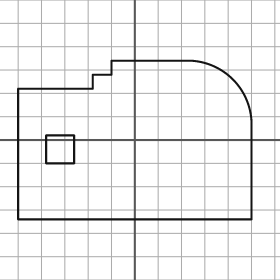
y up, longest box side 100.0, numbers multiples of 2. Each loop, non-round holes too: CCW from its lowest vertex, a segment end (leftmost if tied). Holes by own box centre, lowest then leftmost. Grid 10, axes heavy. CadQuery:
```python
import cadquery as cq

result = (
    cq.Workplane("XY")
    .moveTo(-50.0, -34.0)
    .lineTo(50.0, -34.0)
    .lineTo(50.0, 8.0)
    .threePointArc((42.0, 26.0), (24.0, 34.0))
    .lineTo(-10.0, 34.0)
    .lineTo(-10.0, 28.0)
    .lineTo(-18.0, 28.0)
    .lineTo(-18.0, 22.0)
    .lineTo(-50.0, 22.0)
    .close()
    .moveTo(-38.0, -10.0)
    .lineTo(-26.0, -10.0)
    .lineTo(-26.0, 2.0)
    .lineTo(-38.0, 2.0)
    .close()
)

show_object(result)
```